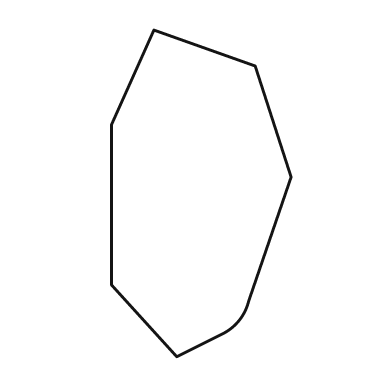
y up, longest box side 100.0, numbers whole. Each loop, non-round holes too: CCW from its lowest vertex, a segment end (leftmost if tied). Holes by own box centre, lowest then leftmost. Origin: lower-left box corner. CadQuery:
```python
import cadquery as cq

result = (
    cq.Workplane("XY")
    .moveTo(20.0, 0.0)
    .lineTo(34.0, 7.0)
    .threePointArc((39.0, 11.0), (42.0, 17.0))
    .lineTo(55.0, 55.0)
    .lineTo(44.0, 89.0)
    .lineTo(13.0, 100.0)
    .lineTo(0.0, 71.0)
    .lineTo(0.0, 22.0)
    .close()
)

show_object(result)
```